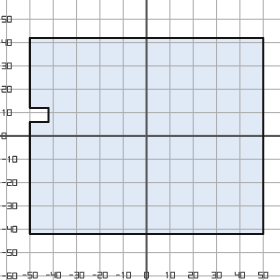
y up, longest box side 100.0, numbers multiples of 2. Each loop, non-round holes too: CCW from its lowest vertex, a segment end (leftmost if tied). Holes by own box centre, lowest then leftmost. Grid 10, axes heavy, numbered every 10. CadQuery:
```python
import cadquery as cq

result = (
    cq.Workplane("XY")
    .moveTo(-50.0, -42.0)
    .lineTo(50.0, -42.0)
    .lineTo(50.0, 42.0)
    .lineTo(-50.0, 42.0)
    .lineTo(-50.0, 12.0)
    .lineTo(-42.0, 12.0)
    .lineTo(-42.0, 6.0)
    .lineTo(-50.0, 6.0)
    .close()
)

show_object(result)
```